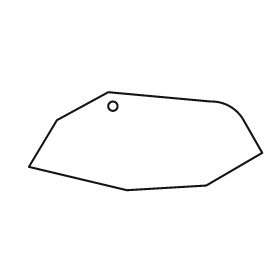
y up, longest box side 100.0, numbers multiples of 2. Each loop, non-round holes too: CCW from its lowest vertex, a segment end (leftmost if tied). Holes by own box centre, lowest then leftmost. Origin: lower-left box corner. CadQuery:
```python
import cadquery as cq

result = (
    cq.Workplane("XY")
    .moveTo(42.0, 0.0)
    .lineTo(76.0, 2.0)
    .lineTo(100.0, 16.0)
    .lineTo(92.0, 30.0)
    .threePointArc((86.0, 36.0), (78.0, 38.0))
    .lineTo(34.0, 42.0)
    .lineTo(12.0, 30.0)
    .lineTo(0.0, 10.0)
    .close()
    .moveTo(36.0, 36.0)
    .circle(2.0)
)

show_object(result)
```